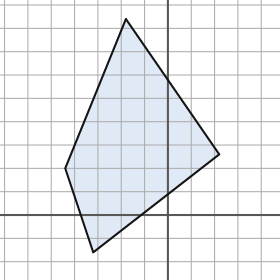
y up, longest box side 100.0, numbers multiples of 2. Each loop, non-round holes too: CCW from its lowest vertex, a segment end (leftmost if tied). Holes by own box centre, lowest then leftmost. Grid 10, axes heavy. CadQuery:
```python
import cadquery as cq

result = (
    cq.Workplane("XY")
    .moveTo(-32.0, -16.0)
    .lineTo(22.0, 26.0)
    .lineTo(-18.0, 84.0)
    .lineTo(-44.0, 20.0)
    .close()
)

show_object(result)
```